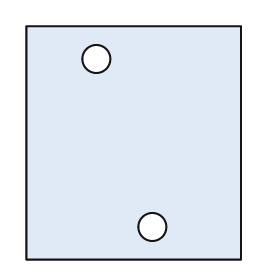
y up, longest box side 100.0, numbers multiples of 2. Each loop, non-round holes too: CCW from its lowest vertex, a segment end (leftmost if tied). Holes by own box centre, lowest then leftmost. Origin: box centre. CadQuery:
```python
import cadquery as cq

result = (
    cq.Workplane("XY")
    .moveTo(-46.0, -50.0)
    .lineTo(46.0, -50.0)
    .lineTo(46.0, 50.0)
    .lineTo(-46.0, 50.0)
    .close()
    .moveTo(8.0, -36.0)
    .circle(6.0)
    .moveTo(-16.0, 36.0)
    .circle(6.0)
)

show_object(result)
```